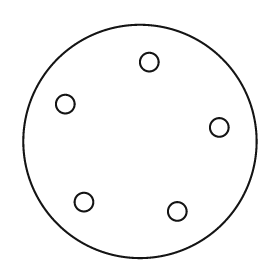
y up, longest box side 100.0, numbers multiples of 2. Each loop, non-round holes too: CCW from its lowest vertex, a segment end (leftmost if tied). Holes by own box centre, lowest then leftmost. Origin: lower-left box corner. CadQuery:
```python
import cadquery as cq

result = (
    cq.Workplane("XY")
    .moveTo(50.0, 50.0)
    .circle(50.0)
    .moveTo(66.0, 20.0)
    .circle(4.0)
    .moveTo(26.0, 24.0)
    .circle(4.0)
    .moveTo(84.0, 56.0)
    .circle(4.0)
    .moveTo(18.0, 66.0)
    .circle(4.0)
    .moveTo(54.0, 84.0)
    .circle(4.0)
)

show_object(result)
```